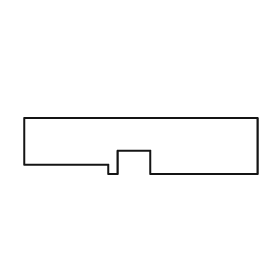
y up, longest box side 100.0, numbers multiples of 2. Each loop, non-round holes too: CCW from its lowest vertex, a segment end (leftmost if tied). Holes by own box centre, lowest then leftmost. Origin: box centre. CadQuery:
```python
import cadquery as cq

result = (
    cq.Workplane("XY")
    .moveTo(-14.0, -12.0)
    .lineTo(-10.0, -12.0)
    .lineTo(-10.0, -2.0)
    .lineTo(4.0, -2.0)
    .lineTo(4.0, -12.0)
    .lineTo(50.0, -12.0)
    .lineTo(50.0, 12.0)
    .lineTo(-50.0, 12.0)
    .lineTo(-50.0, -8.0)
    .lineTo(-14.0, -8.0)
    .close()
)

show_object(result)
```